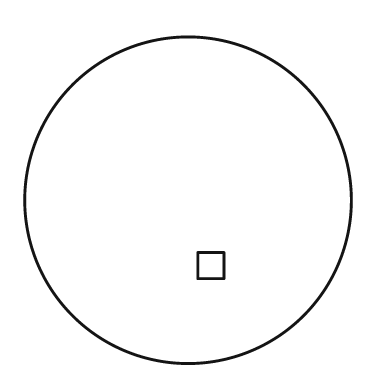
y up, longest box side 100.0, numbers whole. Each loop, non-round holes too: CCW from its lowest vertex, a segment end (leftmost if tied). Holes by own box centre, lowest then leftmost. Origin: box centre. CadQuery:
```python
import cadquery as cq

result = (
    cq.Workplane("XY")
    .moveTo(0.0, 0.0)
    .circle(50.0)
    .moveTo(3.0, -24.0)
    .lineTo(11.0, -24.0)
    .lineTo(11.0, -16.0)
    .lineTo(3.0, -16.0)
    .close()
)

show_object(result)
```